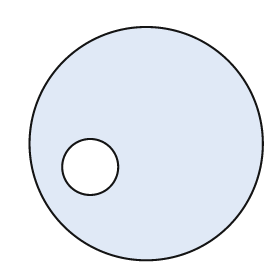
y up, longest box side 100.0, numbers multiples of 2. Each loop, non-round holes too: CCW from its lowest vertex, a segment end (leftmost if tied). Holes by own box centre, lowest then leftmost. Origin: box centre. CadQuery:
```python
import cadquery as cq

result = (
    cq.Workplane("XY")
    .moveTo(0.0, 0.0)
    .circle(50.0)
    .moveTo(-24.0, -10.0)
    .circle(12.0)
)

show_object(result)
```